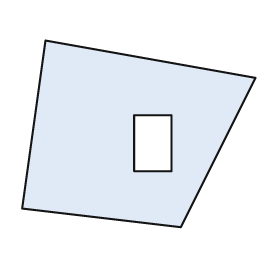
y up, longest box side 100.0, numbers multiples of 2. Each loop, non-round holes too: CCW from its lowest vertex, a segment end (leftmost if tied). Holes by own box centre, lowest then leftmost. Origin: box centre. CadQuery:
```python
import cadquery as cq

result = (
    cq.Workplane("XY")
    .moveTo(18.0, -40.0)
    .lineTo(50.0, 24.0)
    .lineTo(-40.0, 40.0)
    .lineTo(-50.0, -32.0)
    .close()
    .moveTo(-2.0, -16.0)
    .lineTo(14.0, -16.0)
    .lineTo(14.0, 8.0)
    .lineTo(-2.0, 8.0)
    .close()
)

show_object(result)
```